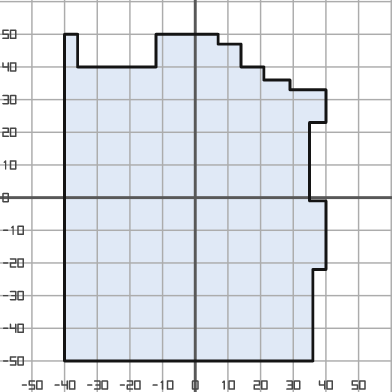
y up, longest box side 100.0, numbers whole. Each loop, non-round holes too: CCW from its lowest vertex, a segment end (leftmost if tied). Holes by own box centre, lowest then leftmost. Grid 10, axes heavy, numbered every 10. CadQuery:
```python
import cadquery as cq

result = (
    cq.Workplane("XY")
    .moveTo(-40.0, -50.0)
    .lineTo(36.0, -50.0)
    .lineTo(36.0, -22.0)
    .lineTo(40.0, -22.0)
    .lineTo(40.0, -1.0)
    .lineTo(35.0, -1.0)
    .lineTo(35.0, 23.0)
    .lineTo(40.0, 23.0)
    .lineTo(40.0, 33.0)
    .lineTo(29.0, 33.0)
    .lineTo(29.0, 36.0)
    .lineTo(21.0, 36.0)
    .lineTo(21.0, 40.0)
    .lineTo(14.0, 40.0)
    .lineTo(14.0, 47.0)
    .lineTo(7.0, 47.0)
    .lineTo(7.0, 50.0)
    .lineTo(-12.0, 50.0)
    .lineTo(-12.0, 40.0)
    .lineTo(-36.0, 40.0)
    .lineTo(-36.0, 50.0)
    .lineTo(-40.0, 50.0)
    .close()
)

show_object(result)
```